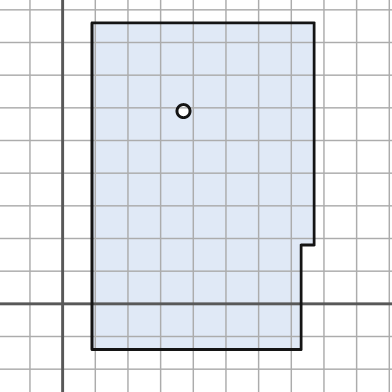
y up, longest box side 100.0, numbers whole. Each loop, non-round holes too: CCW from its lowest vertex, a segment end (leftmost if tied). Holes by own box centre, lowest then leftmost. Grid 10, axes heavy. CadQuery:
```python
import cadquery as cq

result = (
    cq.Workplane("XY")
    .moveTo(9.0, -14.0)
    .lineTo(73.0, -14.0)
    .lineTo(73.0, 18.0)
    .lineTo(77.0, 18.0)
    .lineTo(77.0, 86.0)
    .lineTo(9.0, 86.0)
    .close()
    .moveTo(37.0, 59.0)
    .circle(2.0)
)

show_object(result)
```